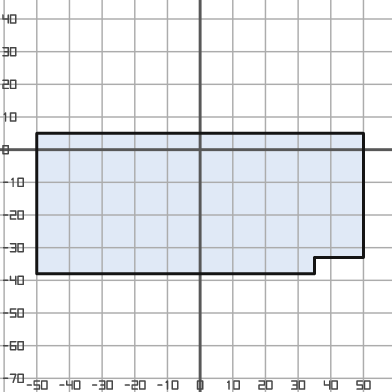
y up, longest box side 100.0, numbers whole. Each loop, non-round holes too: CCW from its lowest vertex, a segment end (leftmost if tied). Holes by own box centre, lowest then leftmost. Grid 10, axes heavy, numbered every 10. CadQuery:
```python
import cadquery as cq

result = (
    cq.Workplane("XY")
    .moveTo(-50.0, -38.0)
    .lineTo(35.0, -38.0)
    .lineTo(35.0, -33.0)
    .lineTo(50.0, -33.0)
    .lineTo(50.0, 5.0)
    .lineTo(-50.0, 5.0)
    .close()
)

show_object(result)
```